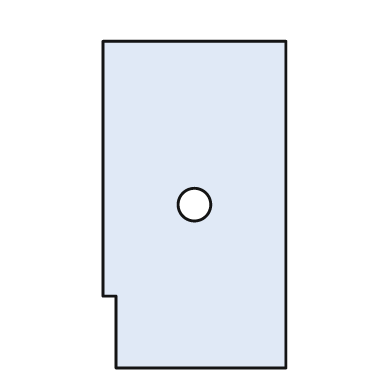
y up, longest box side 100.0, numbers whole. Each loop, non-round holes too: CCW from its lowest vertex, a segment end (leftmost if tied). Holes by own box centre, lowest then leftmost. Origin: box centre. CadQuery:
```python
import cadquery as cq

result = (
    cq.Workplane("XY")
    .moveTo(-24.0, -50.0)
    .lineTo(28.0, -50.0)
    .lineTo(28.0, 50.0)
    .lineTo(-28.0, 50.0)
    .lineTo(-28.0, -28.0)
    .lineTo(-24.0, -28.0)
    .close()
    .moveTo(0.0, 0.0)
    .circle(5.0)
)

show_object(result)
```